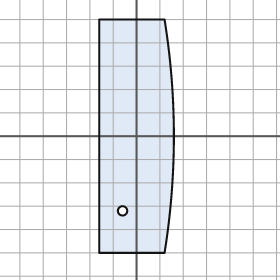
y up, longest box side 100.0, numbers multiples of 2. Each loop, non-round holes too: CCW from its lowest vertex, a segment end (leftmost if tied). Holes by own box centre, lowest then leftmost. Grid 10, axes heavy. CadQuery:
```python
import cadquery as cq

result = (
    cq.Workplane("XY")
    .moveTo(-16.0, -50.0)
    .lineTo(12.0, -50.0)
    .threePointArc((16.0, 0.0), (12.0, 50.0))
    .lineTo(-16.0, 50.0)
    .close()
    .moveTo(-6.0, -32.0)
    .circle(2.0)
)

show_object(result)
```